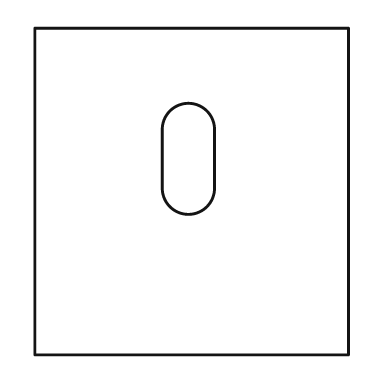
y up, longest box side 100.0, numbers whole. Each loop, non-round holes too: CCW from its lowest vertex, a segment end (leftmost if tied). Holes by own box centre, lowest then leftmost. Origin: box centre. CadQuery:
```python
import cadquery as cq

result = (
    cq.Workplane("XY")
    .moveTo(-48.0, -50.0)
    .lineTo(48.0, -50.0)
    .lineTo(48.0, 50.0)
    .lineTo(-48.0, 50.0)
    .close()
    .moveTo(-9.0, 1.0)
    .threePointArc((-1.0, -7.0), (7.0, 1.0))
    .lineTo(7.0, 19.0)
    .threePointArc((-1.0, 27.0), (-9.0, 19.0))
    .close()
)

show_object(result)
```